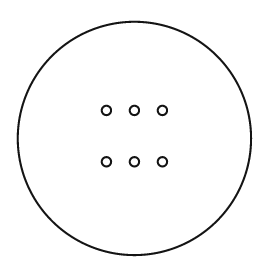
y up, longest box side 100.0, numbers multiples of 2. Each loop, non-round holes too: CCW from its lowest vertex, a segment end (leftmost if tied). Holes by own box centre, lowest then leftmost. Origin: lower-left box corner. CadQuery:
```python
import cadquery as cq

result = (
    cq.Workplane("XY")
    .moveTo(50.0, 50.0)
    .circle(50.0)
    .moveTo(38.0, 40.0)
    .circle(2.0)
    .moveTo(50.0, 40.0)
    .circle(2.0)
    .moveTo(62.0, 40.0)
    .circle(2.0)
    .moveTo(38.0, 62.0)
    .circle(2.0)
    .moveTo(50.0, 62.0)
    .circle(2.0)
    .moveTo(62.0, 62.0)
    .circle(2.0)
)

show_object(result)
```